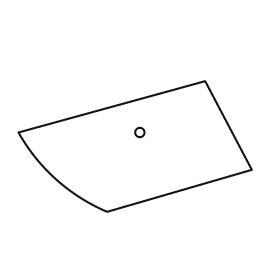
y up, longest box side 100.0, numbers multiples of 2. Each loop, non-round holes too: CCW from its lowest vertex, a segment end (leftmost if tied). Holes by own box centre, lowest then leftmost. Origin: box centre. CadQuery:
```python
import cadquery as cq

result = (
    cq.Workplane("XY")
    .moveTo(-12.0, -28.0)
    .lineTo(50.0, -10.0)
    .lineTo(30.0, 28.0)
    .lineTo(-50.0, 6.0)
    .threePointArc((-34.0, -14.0), (-12.0, -28.0))
    .close()
    .moveTo(2.0, 6.0)
    .circle(2.0)
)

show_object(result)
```